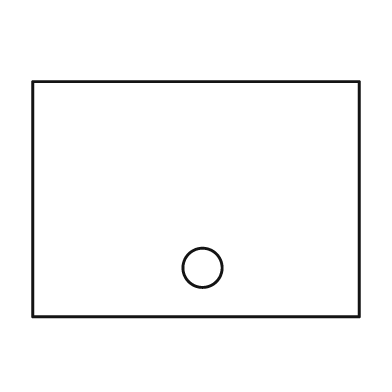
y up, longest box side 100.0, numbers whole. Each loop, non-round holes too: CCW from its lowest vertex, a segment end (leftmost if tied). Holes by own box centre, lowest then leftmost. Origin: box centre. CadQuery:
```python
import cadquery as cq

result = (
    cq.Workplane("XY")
    .moveTo(-50.0, -36.0)
    .lineTo(50.0, -36.0)
    .lineTo(50.0, 36.0)
    .lineTo(-50.0, 36.0)
    .close()
    .moveTo(2.0, -21.0)
    .circle(6.0)
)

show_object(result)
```